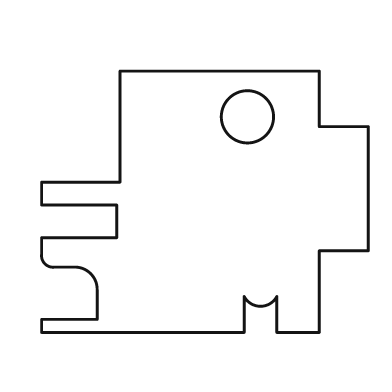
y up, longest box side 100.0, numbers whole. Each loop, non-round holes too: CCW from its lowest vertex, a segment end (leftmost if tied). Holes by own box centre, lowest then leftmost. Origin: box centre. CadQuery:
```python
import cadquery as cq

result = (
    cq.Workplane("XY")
    .moveTo(-50.0, -40.0)
    .lineTo(12.0, -40.0)
    .lineTo(12.0, -29.0)
    .threePointArc((17.0, -32.0), (22.0, -29.0))
    .lineTo(22.0, -40.0)
    .lineTo(35.0, -40.0)
    .lineTo(35.0, -15.0)
    .lineTo(50.0, -15.0)
    .lineTo(50.0, 23.0)
    .lineTo(35.0, 23.0)
    .lineTo(35.0, 40.0)
    .lineTo(-26.0, 40.0)
    .lineTo(-26.0, 6.0)
    .lineTo(-50.0, 6.0)
    .lineTo(-50.0, -1.0)
    .lineTo(-27.0, -1.0)
    .lineTo(-27.0, -11.0)
    .lineTo(-50.0, -11.0)
    .lineTo(-50.0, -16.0)
    .threePointArc((-49.0, -19.0), (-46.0, -20.0))
    .lineTo(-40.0, -20.0)
    .threePointArc((-35.0, -22.0), (-33.0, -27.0))
    .lineTo(-33.0, -36.0)
    .lineTo(-50.0, -36.0)
    .close()
    .moveTo(13.0, 26.0)
    .circle(8.0)
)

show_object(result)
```